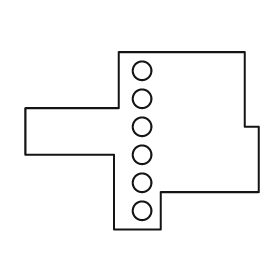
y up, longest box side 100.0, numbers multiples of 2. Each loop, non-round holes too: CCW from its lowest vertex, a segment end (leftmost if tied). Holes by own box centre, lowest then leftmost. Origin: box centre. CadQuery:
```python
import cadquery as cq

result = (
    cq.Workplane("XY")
    .moveTo(-12.0, -38.0)
    .lineTo(8.0, -38.0)
    .lineTo(8.0, -22.0)
    .lineTo(50.0, -22.0)
    .lineTo(50.0, 6.0)
    .lineTo(44.0, 6.0)
    .lineTo(44.0, 38.0)
    .lineTo(-10.0, 38.0)
    .lineTo(-10.0, 14.0)
    .lineTo(-50.0, 14.0)
    .lineTo(-50.0, -6.0)
    .lineTo(-12.0, -6.0)
    .close()
    .moveTo(0.0, -30.0)
    .circle(4.0)
    .moveTo(0.0, -18.0)
    .circle(4.0)
    .moveTo(0.0, -6.0)
    .circle(4.0)
    .moveTo(0.0, 6.0)
    .circle(4.0)
    .moveTo(0.0, 18.0)
    .circle(4.0)
    .moveTo(0.0, 30.0)
    .circle(4.0)
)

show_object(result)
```